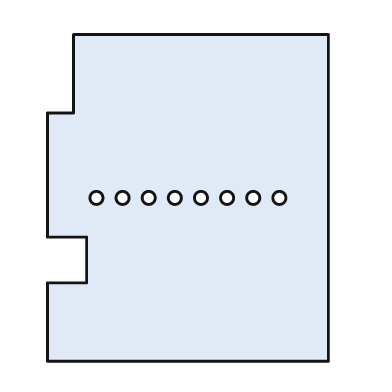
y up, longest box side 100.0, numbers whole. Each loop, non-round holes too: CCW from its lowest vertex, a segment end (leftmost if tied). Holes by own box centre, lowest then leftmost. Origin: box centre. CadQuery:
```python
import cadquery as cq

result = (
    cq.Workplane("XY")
    .moveTo(-43.0, -50.0)
    .lineTo(43.0, -50.0)
    .lineTo(43.0, 50.0)
    .lineTo(-35.0, 50.0)
    .lineTo(-35.0, 26.0)
    .lineTo(-43.0, 26.0)
    .lineTo(-43.0, -12.0)
    .lineTo(-31.0, -12.0)
    .lineTo(-31.0, -26.0)
    .lineTo(-43.0, -26.0)
    .close()
    .moveTo(-28.0, 0.0)
    .circle(2.0)
    .moveTo(-20.0, 0.0)
    .circle(2.0)
    .moveTo(-12.0, 0.0)
    .circle(2.0)
    .moveTo(-4.0, 0.0)
    .circle(2.0)
    .moveTo(4.0, 0.0)
    .circle(2.0)
    .moveTo(12.0, 0.0)
    .circle(2.0)
    .moveTo(20.0, 0.0)
    .circle(2.0)
    .moveTo(28.0, 0.0)
    .circle(2.0)
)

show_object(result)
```